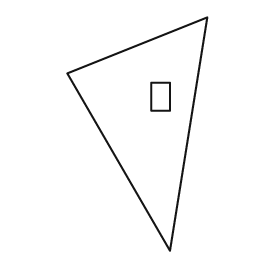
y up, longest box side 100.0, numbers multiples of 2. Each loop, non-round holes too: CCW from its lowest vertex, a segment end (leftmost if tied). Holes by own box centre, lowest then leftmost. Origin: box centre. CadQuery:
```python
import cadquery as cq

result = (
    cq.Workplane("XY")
    .moveTo(14.0, -50.0)
    .lineTo(30.0, 50.0)
    .lineTo(-30.0, 26.0)
    .close()
    .moveTo(6.0, 10.0)
    .lineTo(14.0, 10.0)
    .lineTo(14.0, 22.0)
    .lineTo(6.0, 22.0)
    .close()
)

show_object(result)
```